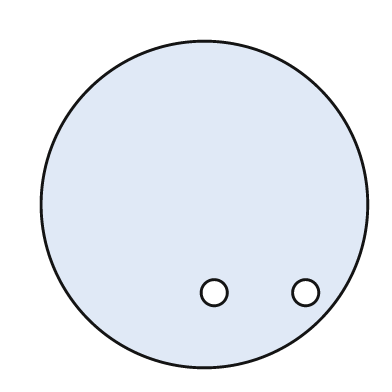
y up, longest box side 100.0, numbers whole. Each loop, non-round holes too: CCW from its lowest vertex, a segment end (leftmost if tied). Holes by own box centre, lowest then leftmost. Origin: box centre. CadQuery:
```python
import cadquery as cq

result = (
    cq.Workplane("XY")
    .moveTo(0.0, 0.0)
    .circle(50.0)
    .moveTo(3.0, -27.0)
    .circle(4.0)
    .moveTo(31.0, -27.0)
    .circle(4.0)
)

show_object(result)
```